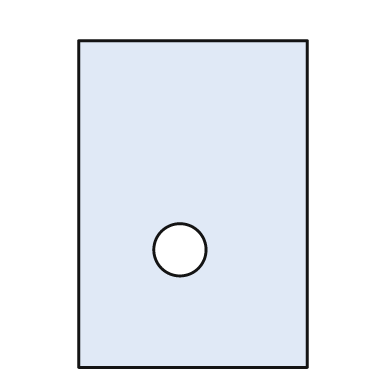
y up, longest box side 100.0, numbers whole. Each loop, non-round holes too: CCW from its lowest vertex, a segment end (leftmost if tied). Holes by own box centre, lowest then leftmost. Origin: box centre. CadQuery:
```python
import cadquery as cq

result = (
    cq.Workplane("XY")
    .moveTo(-35.0, -50.0)
    .lineTo(35.0, -50.0)
    .lineTo(35.0, 50.0)
    .lineTo(-35.0, 50.0)
    .close()
    .moveTo(-4.0, -14.0)
    .circle(8.0)
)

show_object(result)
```